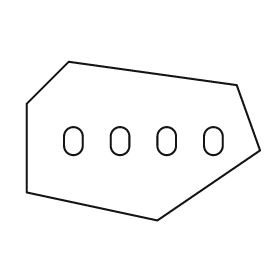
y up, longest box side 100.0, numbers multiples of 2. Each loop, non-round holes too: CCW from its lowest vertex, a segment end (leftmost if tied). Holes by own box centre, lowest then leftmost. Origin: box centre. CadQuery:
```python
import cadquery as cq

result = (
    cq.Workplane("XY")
    .moveTo(6.0, -34.0)
    .lineTo(50.0, -4.0)
    .lineTo(40.0, 24.0)
    .lineTo(-32.0, 34.0)
    .lineTo(-50.0, 16.0)
    .lineTo(-50.0, -22.0)
    .close()
    .moveTo(-34.0, -2.0)
    .threePointArc((-30.0, -6.0), (-26.0, -2.0))
    .lineTo(-26.0, 2.0)
    .threePointArc((-30.0, 6.0), (-34.0, 2.0))
    .close()
    .moveTo(-14.0, -2.0)
    .threePointArc((-10.0, -6.0), (-6.0, -2.0))
    .lineTo(-6.0, 2.0)
    .threePointArc((-10.0, 6.0), (-14.0, 2.0))
    .close()
    .moveTo(6.0, -2.0)
    .threePointArc((10.0, -6.0), (14.0, -2.0))
    .lineTo(14.0, 2.0)
    .threePointArc((10.0, 6.0), (6.0, 2.0))
    .close()
    .moveTo(26.0, -2.0)
    .threePointArc((30.0, -6.0), (34.0, -2.0))
    .lineTo(34.0, 2.0)
    .threePointArc((30.0, 6.0), (26.0, 2.0))
    .close()
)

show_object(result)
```